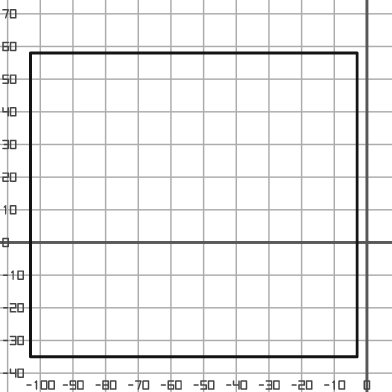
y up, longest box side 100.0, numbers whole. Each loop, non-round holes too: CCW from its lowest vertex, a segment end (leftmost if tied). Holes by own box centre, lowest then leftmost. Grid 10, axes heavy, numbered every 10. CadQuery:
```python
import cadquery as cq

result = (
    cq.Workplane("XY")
    .moveTo(-103.0, -35.0)
    .lineTo(-3.0, -35.0)
    .lineTo(-3.0, 58.0)
    .lineTo(-103.0, 58.0)
    .close()
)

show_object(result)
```